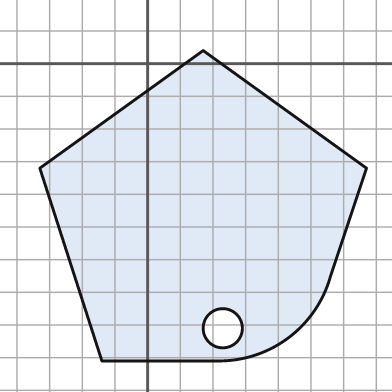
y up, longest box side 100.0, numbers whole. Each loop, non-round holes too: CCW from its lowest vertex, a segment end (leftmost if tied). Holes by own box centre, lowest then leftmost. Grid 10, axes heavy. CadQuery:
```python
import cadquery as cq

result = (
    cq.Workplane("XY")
    .moveTo(-14.0, -91.0)
    .lineTo(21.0, -91.0)
    .threePointArc((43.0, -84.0), (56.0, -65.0))
    .lineTo(67.0, -32.0)
    .lineTo(17.0, 4.0)
    .lineTo(-33.0, -32.0)
    .close()
    .moveTo(23.0, -81.0)
    .circle(6.0)
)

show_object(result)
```